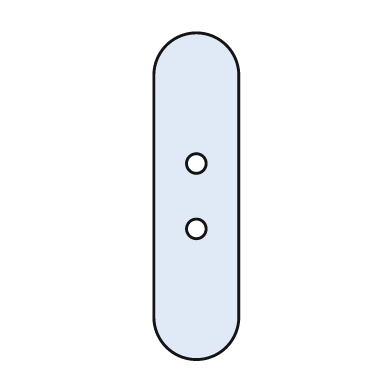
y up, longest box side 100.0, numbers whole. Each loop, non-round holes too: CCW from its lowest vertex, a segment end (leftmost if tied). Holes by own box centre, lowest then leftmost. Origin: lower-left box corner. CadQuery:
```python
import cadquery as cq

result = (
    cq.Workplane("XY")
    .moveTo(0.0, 13.0)
    .threePointArc((13.0, 0.0), (26.0, 13.0))
    .lineTo(26.0, 87.0)
    .threePointArc((13.0, 100.0), (0.0, 87.0))
    .close()
    .moveTo(13.0, 40.0)
    .circle(3.0)
    .moveTo(13.0, 60.0)
    .circle(3.0)
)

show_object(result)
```